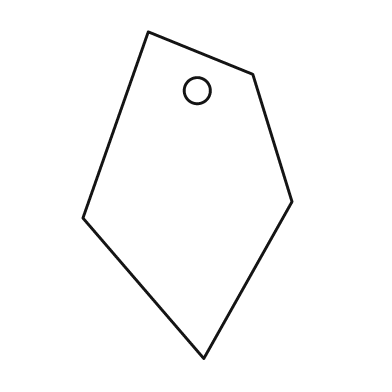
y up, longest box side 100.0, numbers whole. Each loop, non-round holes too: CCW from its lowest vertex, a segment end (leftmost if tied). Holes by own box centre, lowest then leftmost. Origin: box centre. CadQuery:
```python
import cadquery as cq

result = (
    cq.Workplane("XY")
    .moveTo(5.0, -50.0)
    .lineTo(32.0, -2.0)
    .lineTo(20.0, 37.0)
    .lineTo(-12.0, 50.0)
    .lineTo(-32.0, -7.0)
    .close()
    .moveTo(3.0, 32.0)
    .circle(4.0)
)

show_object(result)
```